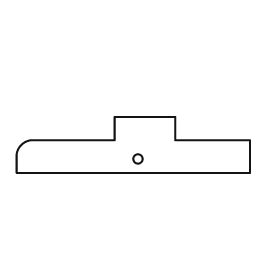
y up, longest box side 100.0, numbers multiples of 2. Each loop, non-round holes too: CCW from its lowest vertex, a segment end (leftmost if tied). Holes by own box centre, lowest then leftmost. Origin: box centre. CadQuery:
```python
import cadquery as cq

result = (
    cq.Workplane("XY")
    .moveTo(-50.0, -12.0)
    .lineTo(50.0, -12.0)
    .lineTo(50.0, 2.0)
    .lineTo(18.0, 2.0)
    .lineTo(18.0, 12.0)
    .lineTo(-8.0, 12.0)
    .lineTo(-8.0, 2.0)
    .lineTo(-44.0, 2.0)
    .threePointArc((-48.0, 0.0), (-50.0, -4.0))
    .close()
    .moveTo(2.0, -6.0)
    .circle(2.0)
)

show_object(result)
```